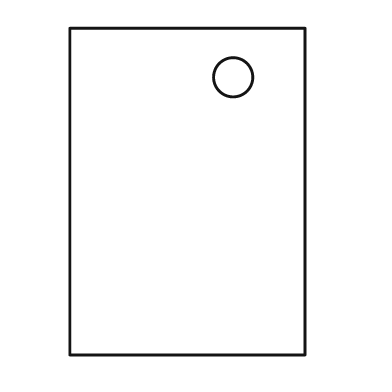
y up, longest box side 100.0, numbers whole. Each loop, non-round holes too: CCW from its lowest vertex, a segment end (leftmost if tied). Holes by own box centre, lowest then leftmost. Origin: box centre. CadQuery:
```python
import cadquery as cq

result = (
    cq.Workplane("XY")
    .moveTo(-36.0, -50.0)
    .lineTo(36.0, -50.0)
    .lineTo(36.0, 50.0)
    .lineTo(-36.0, 50.0)
    .close()
    .moveTo(14.0, 35.0)
    .circle(6.0)
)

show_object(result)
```